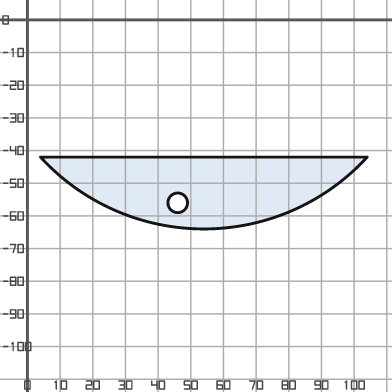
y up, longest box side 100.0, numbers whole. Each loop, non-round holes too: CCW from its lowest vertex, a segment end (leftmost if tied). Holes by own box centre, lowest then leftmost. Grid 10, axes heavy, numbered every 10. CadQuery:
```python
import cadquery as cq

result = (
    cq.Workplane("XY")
    .moveTo(4.0, -42.0)
    .threePointArc((54.0, -64.0), (104.0, -42.0))
    .close()
    .moveTo(46.0, -56.0)
    .circle(3.0)
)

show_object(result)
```